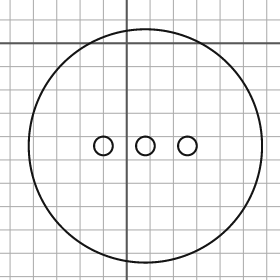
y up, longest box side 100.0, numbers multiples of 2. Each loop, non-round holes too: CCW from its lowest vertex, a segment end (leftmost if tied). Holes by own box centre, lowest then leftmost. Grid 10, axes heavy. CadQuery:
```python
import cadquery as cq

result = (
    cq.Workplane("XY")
    .moveTo(8.0, -44.0)
    .circle(50.0)
    .moveTo(-10.0, -44.0)
    .circle(4.0)
    .moveTo(8.0, -44.0)
    .circle(4.0)
    .moveTo(26.0, -44.0)
    .circle(4.0)
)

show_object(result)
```